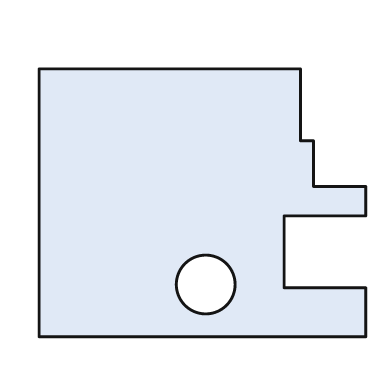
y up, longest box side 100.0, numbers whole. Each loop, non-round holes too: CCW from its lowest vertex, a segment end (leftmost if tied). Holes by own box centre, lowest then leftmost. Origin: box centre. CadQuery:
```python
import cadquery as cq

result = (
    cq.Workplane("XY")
    .moveTo(-50.0, -41.0)
    .lineTo(50.0, -41.0)
    .lineTo(50.0, -26.0)
    .lineTo(25.0, -26.0)
    .lineTo(25.0, -4.0)
    .lineTo(50.0, -4.0)
    .lineTo(50.0, 5.0)
    .lineTo(34.0, 5.0)
    .lineTo(34.0, 19.0)
    .lineTo(30.0, 19.0)
    .lineTo(30.0, 41.0)
    .lineTo(-50.0, 41.0)
    .close()
    .moveTo(1.0, -25.0)
    .circle(9.0)
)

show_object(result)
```